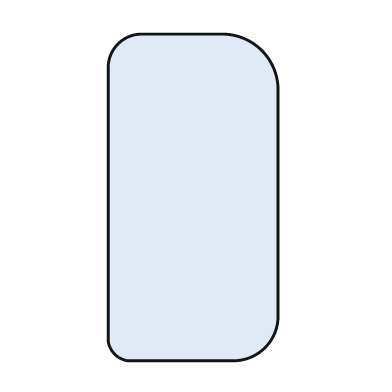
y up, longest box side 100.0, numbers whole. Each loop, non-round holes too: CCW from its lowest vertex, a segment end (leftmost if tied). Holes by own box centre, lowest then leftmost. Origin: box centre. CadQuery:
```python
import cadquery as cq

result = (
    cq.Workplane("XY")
    .moveTo(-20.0, -50.0)
    .lineTo(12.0, -50.0)
    .threePointArc((22.0, -46.0), (26.0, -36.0))
    .lineTo(26.0, 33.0)
    .threePointArc((21.0, 45.0), (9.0, 50.0))
    .lineTo(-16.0, 50.0)
    .threePointArc((-23.0, 47.0), (-26.0, 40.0))
    .lineTo(-26.0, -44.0)
    .threePointArc((-24.0, -48.0), (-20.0, -50.0))
    .close()
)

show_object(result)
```